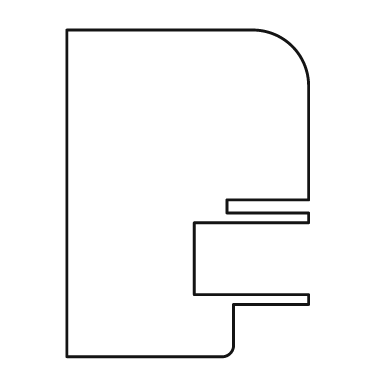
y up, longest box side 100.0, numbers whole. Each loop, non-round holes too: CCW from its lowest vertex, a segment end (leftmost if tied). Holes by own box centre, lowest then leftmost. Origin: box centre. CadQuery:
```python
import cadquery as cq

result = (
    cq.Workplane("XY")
    .moveTo(-37.0, -50.0)
    .lineTo(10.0, -50.0)
    .threePointArc((13.0, -49.0), (14.0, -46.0))
    .lineTo(14.0, -34.0)
    .lineTo(37.0, -34.0)
    .lineTo(37.0, -31.0)
    .lineTo(2.0, -31.0)
    .lineTo(2.0, -9.0)
    .lineTo(37.0, -9.0)
    .lineTo(37.0, -6.0)
    .lineTo(12.0, -6.0)
    .lineTo(12.0, -2.0)
    .lineTo(37.0, -2.0)
    .lineTo(37.0, 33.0)
    .threePointArc((32.0, 45.0), (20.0, 50.0))
    .lineTo(-37.0, 50.0)
    .close()
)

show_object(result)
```